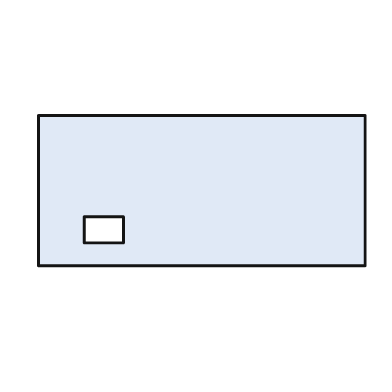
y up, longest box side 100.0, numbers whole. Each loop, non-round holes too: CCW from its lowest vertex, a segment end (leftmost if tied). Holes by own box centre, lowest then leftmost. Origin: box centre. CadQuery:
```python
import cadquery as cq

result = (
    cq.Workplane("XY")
    .moveTo(-50.0, -23.0)
    .lineTo(50.0, -23.0)
    .lineTo(50.0, 23.0)
    .lineTo(-50.0, 23.0)
    .close()
    .moveTo(-36.0, -16.0)
    .lineTo(-24.0, -16.0)
    .lineTo(-24.0, -8.0)
    .lineTo(-36.0, -8.0)
    .close()
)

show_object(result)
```